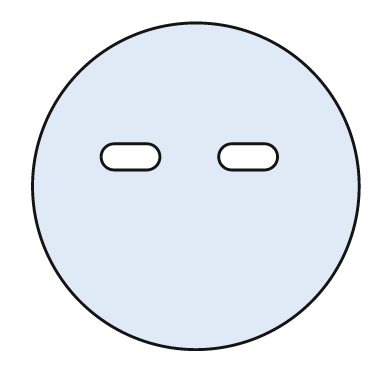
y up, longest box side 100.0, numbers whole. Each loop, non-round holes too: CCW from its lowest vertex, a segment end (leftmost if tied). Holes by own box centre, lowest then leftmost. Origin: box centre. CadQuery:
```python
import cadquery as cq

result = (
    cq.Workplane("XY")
    .moveTo(0.0, 0.0)
    .circle(50.0)
    .moveTo(-25.0, 5.0)
    .lineTo(-15.0, 5.0)
    .threePointArc((-11.0, 9.0), (-15.0, 13.0))
    .lineTo(-25.0, 13.0)
    .threePointArc((-29.0, 9.0), (-25.0, 5.0))
    .close()
    .moveTo(11.0, 5.0)
    .lineTo(21.0, 5.0)
    .threePointArc((25.0, 9.0), (21.0, 13.0))
    .lineTo(11.0, 13.0)
    .threePointArc((7.0, 9.0), (11.0, 5.0))
    .close()
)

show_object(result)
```